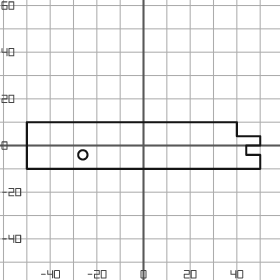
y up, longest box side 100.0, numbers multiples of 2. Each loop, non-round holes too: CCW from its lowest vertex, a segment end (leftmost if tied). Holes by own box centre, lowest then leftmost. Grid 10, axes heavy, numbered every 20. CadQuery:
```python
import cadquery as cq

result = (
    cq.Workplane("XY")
    .moveTo(-50.0, -10.0)
    .lineTo(50.0, -10.0)
    .lineTo(50.0, -4.0)
    .lineTo(44.0, -4.0)
    .lineTo(44.0, 0.0)
    .lineTo(50.0, 0.0)
    .lineTo(50.0, 4.0)
    .lineTo(40.0, 4.0)
    .lineTo(40.0, 10.0)
    .lineTo(-50.0, 10.0)
    .close()
    .moveTo(-26.0, -4.0)
    .circle(2.0)
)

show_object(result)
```